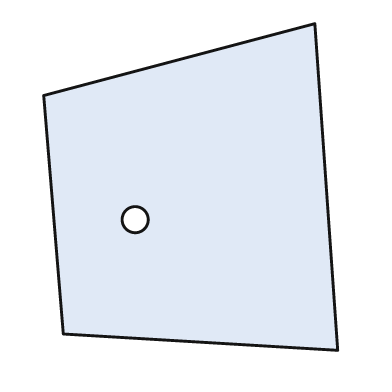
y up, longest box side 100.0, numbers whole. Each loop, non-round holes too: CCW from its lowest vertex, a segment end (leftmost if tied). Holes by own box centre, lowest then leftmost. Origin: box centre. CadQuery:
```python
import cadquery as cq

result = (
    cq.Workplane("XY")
    .moveTo(45.0, -50.0)
    .lineTo(38.0, 50.0)
    .lineTo(-45.0, 28.0)
    .lineTo(-39.0, -45.0)
    .close()
    .moveTo(-17.0, -10.0)
    .circle(4.0)
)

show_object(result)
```